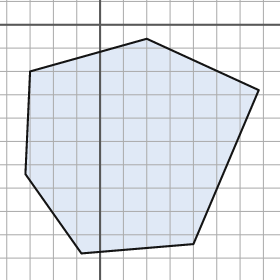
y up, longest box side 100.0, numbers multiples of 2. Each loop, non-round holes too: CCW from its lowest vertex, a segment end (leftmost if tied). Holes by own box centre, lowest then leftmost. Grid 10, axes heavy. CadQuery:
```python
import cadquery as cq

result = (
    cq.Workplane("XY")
    .moveTo(-8.0, -98.0)
    .lineTo(40.0, -94.0)
    .lineTo(68.0, -28.0)
    .lineTo(20.0, -6.0)
    .lineTo(-30.0, -20.0)
    .lineTo(-32.0, -64.0)
    .close()
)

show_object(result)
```